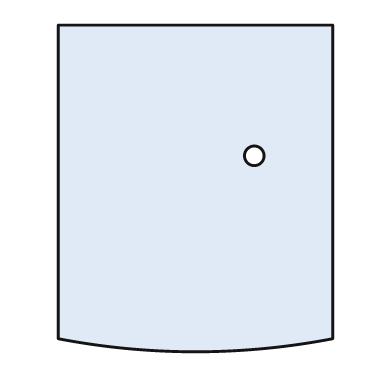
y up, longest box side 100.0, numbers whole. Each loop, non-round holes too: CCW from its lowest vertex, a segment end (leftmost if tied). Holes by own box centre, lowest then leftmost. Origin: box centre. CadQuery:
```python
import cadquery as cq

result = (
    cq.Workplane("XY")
    .moveTo(-42.0, -46.0)
    .threePointArc((0.0, -50.0), (42.0, -46.0))
    .lineTo(42.0, 50.0)
    .lineTo(-42.0, 50.0)
    .close()
    .moveTo(18.0, 10.0)
    .circle(3.0)
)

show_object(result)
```